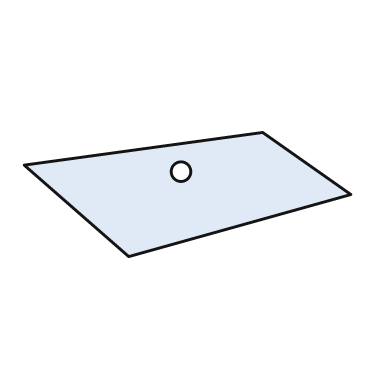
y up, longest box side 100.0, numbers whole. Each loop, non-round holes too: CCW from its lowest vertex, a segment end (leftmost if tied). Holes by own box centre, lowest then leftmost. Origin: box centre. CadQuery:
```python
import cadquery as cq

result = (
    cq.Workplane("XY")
    .moveTo(-18.0, -19.0)
    .lineTo(50.0, 0.0)
    .lineTo(23.0, 19.0)
    .lineTo(-50.0, 9.0)
    .close()
    .moveTo(-2.0, 7.0)
    .circle(3.0)
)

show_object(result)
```